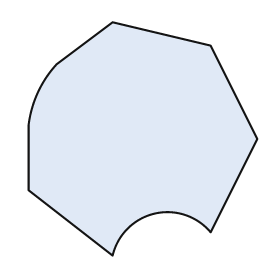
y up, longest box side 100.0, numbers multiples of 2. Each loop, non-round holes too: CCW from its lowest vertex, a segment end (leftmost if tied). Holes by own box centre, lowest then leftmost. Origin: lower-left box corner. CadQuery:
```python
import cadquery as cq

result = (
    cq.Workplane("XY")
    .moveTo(36.0, 0.0)
    .threePointArc((54.0, 18.0), (78.0, 10.0))
    .lineTo(98.0, 50.0)
    .lineTo(78.0, 90.0)
    .lineTo(36.0, 100.0)
    .lineTo(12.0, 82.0)
    .threePointArc((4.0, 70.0), (0.0, 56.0))
    .lineTo(0.0, 28.0)
    .close()
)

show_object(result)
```